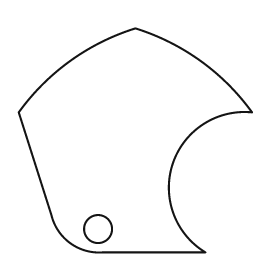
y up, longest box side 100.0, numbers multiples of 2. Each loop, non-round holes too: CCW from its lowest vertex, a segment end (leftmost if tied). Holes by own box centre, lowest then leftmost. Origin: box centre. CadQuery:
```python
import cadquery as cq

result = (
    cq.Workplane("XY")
    .moveTo(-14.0, -48.0)
    .lineTo(30.0, -48.0)
    .threePointArc((16.0, -10.0), (50.0, 12.0))
    .threePointArc((28.0, 34.0), (0.0, 48.0))
    .threePointArc((-28.0, 34.0), (-50.0, 12.0))
    .lineTo(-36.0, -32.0)
    .threePointArc((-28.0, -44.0), (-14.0, -48.0))
    .close()
    .moveTo(-16.0, -38.0)
    .circle(6.0)
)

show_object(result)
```